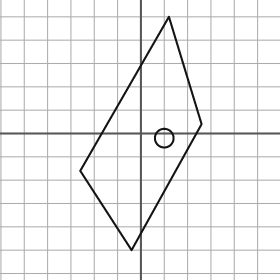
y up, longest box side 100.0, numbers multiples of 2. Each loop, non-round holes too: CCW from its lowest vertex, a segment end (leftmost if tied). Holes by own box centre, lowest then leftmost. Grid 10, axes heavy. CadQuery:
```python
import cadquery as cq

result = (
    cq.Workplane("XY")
    .moveTo(-4.0, -50.0)
    .lineTo(26.0, 4.0)
    .lineTo(12.0, 50.0)
    .lineTo(-26.0, -16.0)
    .close()
    .moveTo(10.0, -2.0)
    .circle(4.0)
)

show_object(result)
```